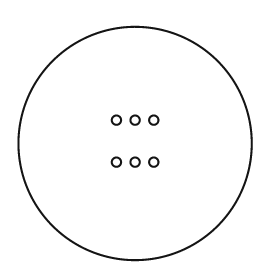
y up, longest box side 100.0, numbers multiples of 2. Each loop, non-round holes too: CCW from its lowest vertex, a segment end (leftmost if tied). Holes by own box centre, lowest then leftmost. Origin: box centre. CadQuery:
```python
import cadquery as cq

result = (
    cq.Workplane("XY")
    .moveTo(0.0, 0.0)
    .circle(50.0)
    .moveTo(-8.0, -8.0)
    .circle(2.0)
    .moveTo(0.0, -8.0)
    .circle(2.0)
    .moveTo(8.0, -8.0)
    .circle(2.0)
    .moveTo(-8.0, 10.0)
    .circle(2.0)
    .moveTo(0.0, 10.0)
    .circle(2.0)
    .moveTo(8.0, 10.0)
    .circle(2.0)
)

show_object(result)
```